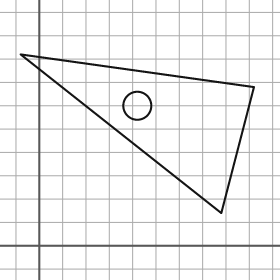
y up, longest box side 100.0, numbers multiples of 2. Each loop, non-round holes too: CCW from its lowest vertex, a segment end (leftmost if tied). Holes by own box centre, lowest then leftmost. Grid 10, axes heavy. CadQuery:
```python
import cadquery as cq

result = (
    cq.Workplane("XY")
    .moveTo(78.0, 14.0)
    .lineTo(92.0, 68.0)
    .lineTo(-8.0, 82.0)
    .close()
    .moveTo(42.0, 60.0)
    .circle(6.0)
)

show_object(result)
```